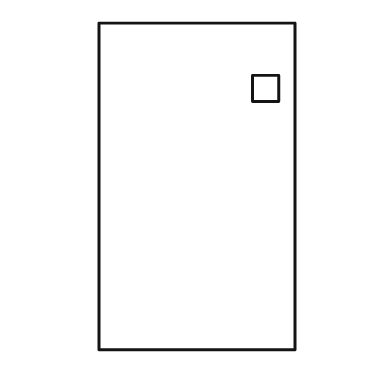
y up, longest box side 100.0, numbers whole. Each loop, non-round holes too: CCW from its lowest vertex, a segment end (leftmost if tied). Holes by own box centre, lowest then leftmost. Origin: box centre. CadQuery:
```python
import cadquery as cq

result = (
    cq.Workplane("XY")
    .moveTo(-30.0, -50.0)
    .lineTo(30.0, -50.0)
    .lineTo(30.0, 50.0)
    .lineTo(-30.0, 50.0)
    .close()
    .moveTo(17.0, 26.0)
    .lineTo(25.0, 26.0)
    .lineTo(25.0, 34.0)
    .lineTo(17.0, 34.0)
    .close()
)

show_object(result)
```